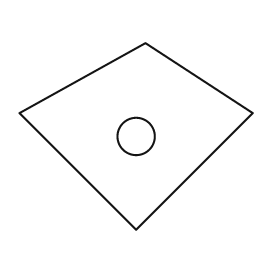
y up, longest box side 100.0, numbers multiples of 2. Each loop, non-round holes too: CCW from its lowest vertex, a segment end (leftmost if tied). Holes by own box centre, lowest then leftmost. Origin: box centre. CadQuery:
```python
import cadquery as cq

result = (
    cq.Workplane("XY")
    .moveTo(0.0, -40.0)
    .lineTo(50.0, 10.0)
    .lineTo(4.0, 40.0)
    .lineTo(-50.0, 10.0)
    .close()
    .moveTo(0.0, 0.0)
    .circle(8.0)
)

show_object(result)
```